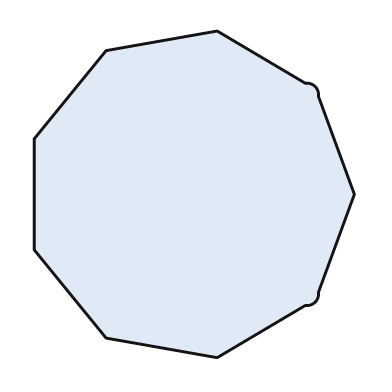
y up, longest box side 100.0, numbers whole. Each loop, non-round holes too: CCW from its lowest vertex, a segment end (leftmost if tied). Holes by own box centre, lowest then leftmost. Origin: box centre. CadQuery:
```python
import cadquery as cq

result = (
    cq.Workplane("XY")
    .moveTo(7.0, -50.0)
    .lineTo(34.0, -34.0)
    .threePointArc((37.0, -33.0), (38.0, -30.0))
    .lineTo(49.0, 0.0)
    .lineTo(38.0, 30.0)
    .threePointArc((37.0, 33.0), (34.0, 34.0))
    .lineTo(7.0, 50.0)
    .lineTo(-27.0, 44.0)
    .lineTo(-49.0, 17.0)
    .lineTo(-49.0, -17.0)
    .lineTo(-27.0, -44.0)
    .close()
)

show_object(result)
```